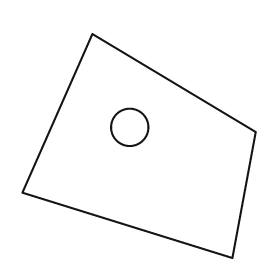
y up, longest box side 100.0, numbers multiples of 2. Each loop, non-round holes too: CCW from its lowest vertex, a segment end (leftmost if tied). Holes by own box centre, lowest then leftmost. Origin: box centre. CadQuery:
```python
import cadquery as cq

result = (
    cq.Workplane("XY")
    .moveTo(40.0, -48.0)
    .lineTo(50.0, 6.0)
    .lineTo(-20.0, 48.0)
    .lineTo(-50.0, -20.0)
    .close()
    .moveTo(-4.0, 8.0)
    .circle(8.0)
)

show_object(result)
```